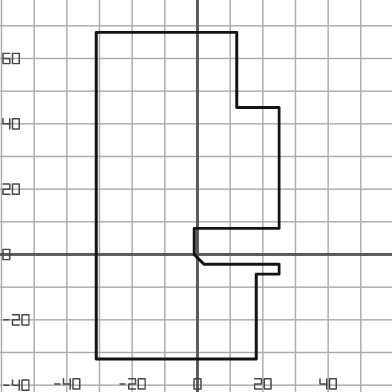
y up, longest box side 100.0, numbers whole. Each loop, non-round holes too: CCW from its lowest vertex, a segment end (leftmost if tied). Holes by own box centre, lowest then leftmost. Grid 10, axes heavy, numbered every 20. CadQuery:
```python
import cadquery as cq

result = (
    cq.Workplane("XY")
    .moveTo(-31.0, -32.0)
    .lineTo(18.0, -32.0)
    .lineTo(18.0, -6.0)
    .lineTo(25.0, -6.0)
    .lineTo(25.0, -3.0)
    .lineTo(2.0, -3.0)
    .lineTo(-1.0, 0.0)
    .lineTo(-1.0, 8.0)
    .lineTo(25.0, 8.0)
    .lineTo(25.0, 45.0)
    .lineTo(12.0, 45.0)
    .lineTo(12.0, 68.0)
    .lineTo(-31.0, 68.0)
    .close()
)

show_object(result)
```